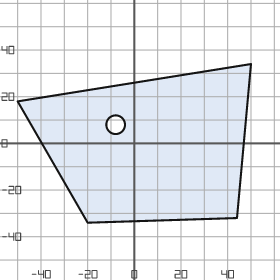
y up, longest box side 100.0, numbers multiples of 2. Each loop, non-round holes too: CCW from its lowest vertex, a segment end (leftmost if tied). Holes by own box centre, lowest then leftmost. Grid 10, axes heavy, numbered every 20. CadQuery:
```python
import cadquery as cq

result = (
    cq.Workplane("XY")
    .moveTo(-20.0, -34.0)
    .lineTo(44.0, -32.0)
    .lineTo(50.0, 34.0)
    .lineTo(-50.0, 18.0)
    .close()
    .moveTo(-8.0, 8.0)
    .circle(4.0)
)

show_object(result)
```